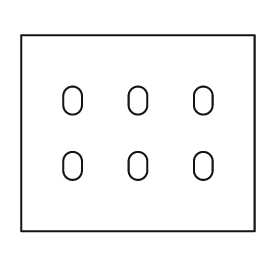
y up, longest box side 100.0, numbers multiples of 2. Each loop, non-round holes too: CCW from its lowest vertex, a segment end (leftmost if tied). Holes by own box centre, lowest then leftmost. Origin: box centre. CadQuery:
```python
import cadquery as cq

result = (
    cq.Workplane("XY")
    .moveTo(-50.0, -42.0)
    .lineTo(50.0, -42.0)
    .lineTo(50.0, 42.0)
    .lineTo(-50.0, 42.0)
    .close()
    .moveTo(-32.0, -16.0)
    .threePointArc((-28.0, -20.0), (-24.0, -16.0))
    .lineTo(-24.0, -12.0)
    .threePointArc((-28.0, -8.0), (-32.0, -12.0))
    .close()
    .moveTo(-4.0, -16.0)
    .threePointArc((0.0, -20.0), (4.0, -16.0))
    .lineTo(4.0, -12.0)
    .threePointArc((0.0, -8.0), (-4.0, -12.0))
    .close()
    .moveTo(24.0, -16.0)
    .threePointArc((28.0, -20.0), (32.0, -16.0))
    .lineTo(32.0, -12.0)
    .threePointArc((28.0, -8.0), (24.0, -12.0))
    .close()
    .moveTo(-32.0, 12.0)
    .threePointArc((-28.0, 8.0), (-24.0, 12.0))
    .lineTo(-24.0, 16.0)
    .threePointArc((-28.0, 20.0), (-32.0, 16.0))
    .close()
    .moveTo(-4.0, 12.0)
    .threePointArc((0.0, 8.0), (4.0, 12.0))
    .lineTo(4.0, 16.0)
    .threePointArc((0.0, 20.0), (-4.0, 16.0))
    .close()
    .moveTo(24.0, 12.0)
    .threePointArc((28.0, 8.0), (32.0, 12.0))
    .lineTo(32.0, 16.0)
    .threePointArc((28.0, 20.0), (24.0, 16.0))
    .close()
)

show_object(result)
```